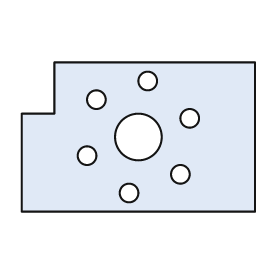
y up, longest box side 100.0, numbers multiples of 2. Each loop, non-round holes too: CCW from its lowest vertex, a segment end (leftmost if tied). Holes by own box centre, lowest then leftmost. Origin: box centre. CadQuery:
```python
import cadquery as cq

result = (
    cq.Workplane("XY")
    .moveTo(-50.0, -32.0)
    .lineTo(50.0, -32.0)
    .lineTo(50.0, 32.0)
    .lineTo(-36.0, 32.0)
    .lineTo(-36.0, 10.0)
    .lineTo(-50.0, 10.0)
    .close()
    .moveTo(-4.0, -24.0)
    .circle(4.0)
    .moveTo(18.0, -16.0)
    .circle(4.0)
    .moveTo(-22.0, -8.0)
    .circle(4.0)
    .moveTo(0.0, 0.0)
    .circle(10.0)
    .moveTo(22.0, 8.0)
    .circle(4.0)
    .moveTo(-18.0, 16.0)
    .circle(4.0)
    .moveTo(4.0, 24.0)
    .circle(4.0)
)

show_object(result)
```